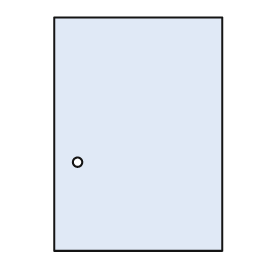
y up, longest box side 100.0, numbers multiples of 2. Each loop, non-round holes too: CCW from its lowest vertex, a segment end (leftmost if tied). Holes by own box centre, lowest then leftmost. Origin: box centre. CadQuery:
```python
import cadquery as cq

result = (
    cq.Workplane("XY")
    .moveTo(-36.0, -50.0)
    .lineTo(36.0, -50.0)
    .lineTo(36.0, 50.0)
    .lineTo(-36.0, 50.0)
    .close()
    .moveTo(-26.0, -12.0)
    .circle(2.0)
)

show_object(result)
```